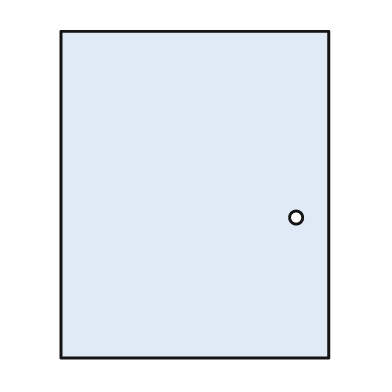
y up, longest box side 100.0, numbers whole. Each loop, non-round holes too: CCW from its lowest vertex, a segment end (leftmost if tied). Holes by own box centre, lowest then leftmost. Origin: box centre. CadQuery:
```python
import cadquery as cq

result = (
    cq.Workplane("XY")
    .moveTo(-41.0, -50.0)
    .lineTo(41.0, -50.0)
    .lineTo(41.0, 50.0)
    .lineTo(-41.0, 50.0)
    .close()
    .moveTo(31.0, -7.0)
    .circle(2.0)
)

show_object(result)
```